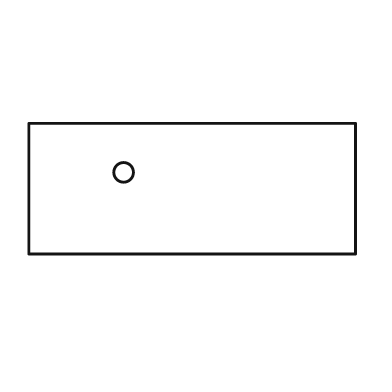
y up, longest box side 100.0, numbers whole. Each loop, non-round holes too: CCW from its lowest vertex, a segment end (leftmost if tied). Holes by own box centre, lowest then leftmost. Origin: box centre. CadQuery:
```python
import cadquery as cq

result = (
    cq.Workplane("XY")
    .moveTo(-50.0, -20.0)
    .lineTo(50.0, -20.0)
    .lineTo(50.0, 20.0)
    .lineTo(-50.0, 20.0)
    .close()
    .moveTo(-21.0, 5.0)
    .circle(3.0)
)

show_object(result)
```